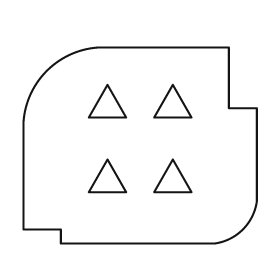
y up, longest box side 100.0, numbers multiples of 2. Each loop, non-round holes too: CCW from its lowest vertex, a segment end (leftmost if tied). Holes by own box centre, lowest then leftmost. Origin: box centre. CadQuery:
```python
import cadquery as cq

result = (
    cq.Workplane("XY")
    .moveTo(-34.0, -42.0)
    .lineTo(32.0, -42.0)
    .threePointArc((44.0, -36.0), (50.0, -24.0))
    .lineTo(50.0, 16.0)
    .lineTo(38.0, 16.0)
    .lineTo(38.0, 42.0)
    .lineTo(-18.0, 42.0)
    .threePointArc((-40.0, 32.0), (-50.0, 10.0))
    .lineTo(-50.0, -36.0)
    .lineTo(-34.0, -36.0)
    .close()
    .moveTo(-22.0, -20.0)
    .lineTo(-6.0, -20.0)
    .lineTo(-14.0, -6.0)
    .close()
    .moveTo(6.0, -20.0)
    .lineTo(22.0, -20.0)
    .lineTo(14.0, -6.0)
    .close()
    .moveTo(-22.0, 12.0)
    .lineTo(-6.0, 12.0)
    .lineTo(-14.0, 26.0)
    .close()
    .moveTo(6.0, 12.0)
    .lineTo(22.0, 12.0)
    .lineTo(14.0, 26.0)
    .close()
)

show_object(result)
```